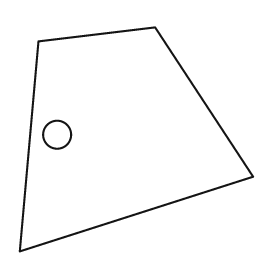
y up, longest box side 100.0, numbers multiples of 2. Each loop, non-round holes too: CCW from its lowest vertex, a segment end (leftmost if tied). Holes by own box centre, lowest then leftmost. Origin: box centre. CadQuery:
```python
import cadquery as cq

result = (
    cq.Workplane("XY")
    .moveTo(-50.0, -48.0)
    .lineTo(50.0, -16.0)
    .lineTo(8.0, 48.0)
    .lineTo(-42.0, 42.0)
    .close()
    .moveTo(-34.0, 2.0)
    .circle(6.0)
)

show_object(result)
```